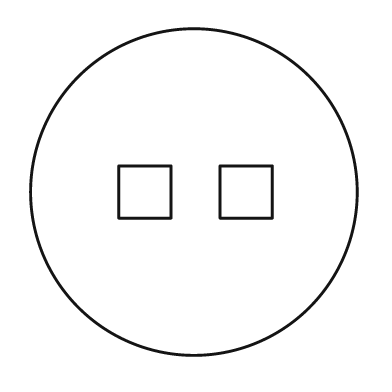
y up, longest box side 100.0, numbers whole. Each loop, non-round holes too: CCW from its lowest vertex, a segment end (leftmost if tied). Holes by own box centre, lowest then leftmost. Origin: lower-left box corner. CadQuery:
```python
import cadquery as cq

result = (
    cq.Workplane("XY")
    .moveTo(50.0, 50.0)
    .circle(50.0)
    .moveTo(27.0, 42.0)
    .lineTo(43.0, 42.0)
    .lineTo(43.0, 58.0)
    .lineTo(27.0, 58.0)
    .close()
    .moveTo(58.0, 42.0)
    .lineTo(74.0, 42.0)
    .lineTo(74.0, 58.0)
    .lineTo(58.0, 58.0)
    .close()
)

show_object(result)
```